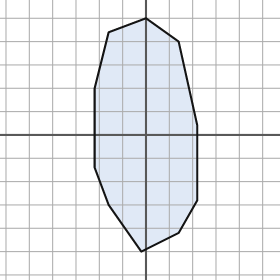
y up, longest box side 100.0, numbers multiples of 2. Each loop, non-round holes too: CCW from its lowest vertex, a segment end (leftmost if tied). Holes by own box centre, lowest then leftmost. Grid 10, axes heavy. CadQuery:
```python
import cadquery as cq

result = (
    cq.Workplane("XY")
    .moveTo(-2.0, -50.0)
    .lineTo(14.0, -42.0)
    .lineTo(22.0, -28.0)
    .lineTo(22.0, 4.0)
    .lineTo(14.0, 40.0)
    .lineTo(0.0, 50.0)
    .lineTo(-16.0, 44.0)
    .lineTo(-22.0, 20.0)
    .lineTo(-22.0, -14.0)
    .lineTo(-16.0, -30.0)
    .close()
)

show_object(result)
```